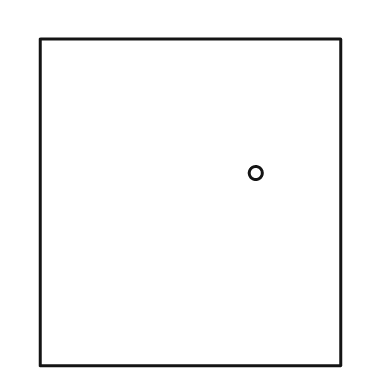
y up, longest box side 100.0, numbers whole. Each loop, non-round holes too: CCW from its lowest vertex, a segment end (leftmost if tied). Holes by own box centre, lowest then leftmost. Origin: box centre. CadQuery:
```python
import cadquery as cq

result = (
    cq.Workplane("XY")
    .moveTo(-46.0, -50.0)
    .lineTo(46.0, -50.0)
    .lineTo(46.0, 50.0)
    .lineTo(-46.0, 50.0)
    .close()
    .moveTo(20.0, 9.0)
    .circle(2.0)
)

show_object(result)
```